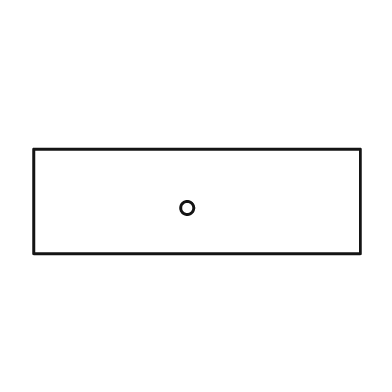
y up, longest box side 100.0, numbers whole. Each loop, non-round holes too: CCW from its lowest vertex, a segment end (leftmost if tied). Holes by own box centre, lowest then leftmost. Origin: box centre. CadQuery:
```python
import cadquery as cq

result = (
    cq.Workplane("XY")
    .moveTo(-50.0, -16.0)
    .lineTo(50.0, -16.0)
    .lineTo(50.0, 16.0)
    .lineTo(-50.0, 16.0)
    .close()
    .moveTo(-3.0, -2.0)
    .circle(2.0)
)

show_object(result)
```